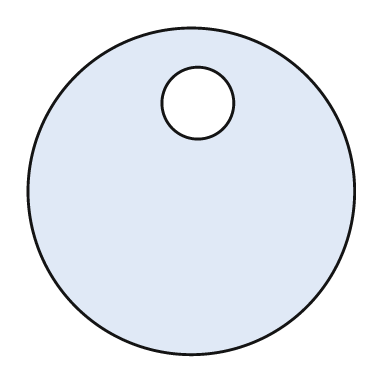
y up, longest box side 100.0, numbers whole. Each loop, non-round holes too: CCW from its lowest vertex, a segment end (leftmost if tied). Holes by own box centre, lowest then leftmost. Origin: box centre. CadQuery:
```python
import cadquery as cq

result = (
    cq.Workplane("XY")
    .moveTo(0.0, 0.0)
    .circle(50.0)
    .moveTo(2.0, 27.0)
    .circle(11.0)
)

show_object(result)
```